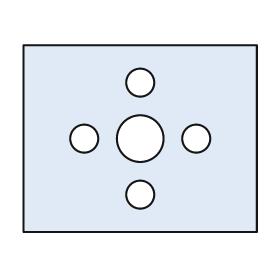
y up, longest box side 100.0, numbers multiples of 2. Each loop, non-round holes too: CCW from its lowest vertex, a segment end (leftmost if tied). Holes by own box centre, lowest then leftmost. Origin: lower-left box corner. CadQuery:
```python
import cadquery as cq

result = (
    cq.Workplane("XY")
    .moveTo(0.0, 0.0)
    .lineTo(100.0, 0.0)
    .lineTo(100.0, 80.0)
    .lineTo(0.0, 80.0)
    .close()
    .moveTo(50.0, 16.0)
    .circle(6.0)
    .moveTo(26.0, 40.0)
    .circle(6.0)
    .moveTo(50.0, 40.0)
    .circle(10.0)
    .moveTo(74.0, 40.0)
    .circle(6.0)
    .moveTo(50.0, 64.0)
    .circle(6.0)
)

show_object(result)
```